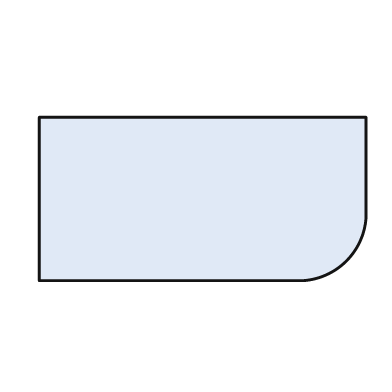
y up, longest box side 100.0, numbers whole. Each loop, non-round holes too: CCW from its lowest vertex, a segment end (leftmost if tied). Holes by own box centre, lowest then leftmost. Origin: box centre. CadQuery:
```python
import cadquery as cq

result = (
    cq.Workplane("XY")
    .moveTo(-50.0, -25.0)
    .lineTo(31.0, -25.0)
    .threePointArc((44.0, -19.0), (50.0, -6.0))
    .lineTo(50.0, 25.0)
    .lineTo(-50.0, 25.0)
    .close()
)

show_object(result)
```